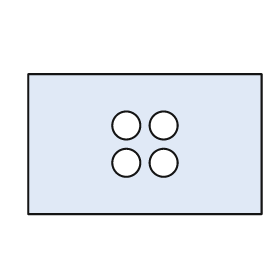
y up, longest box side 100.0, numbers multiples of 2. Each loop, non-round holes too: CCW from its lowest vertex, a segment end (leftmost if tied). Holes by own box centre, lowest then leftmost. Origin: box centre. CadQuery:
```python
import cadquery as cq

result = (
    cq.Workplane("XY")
    .moveTo(-50.0, -30.0)
    .lineTo(50.0, -30.0)
    .lineTo(50.0, 30.0)
    .lineTo(-50.0, 30.0)
    .close()
    .moveTo(-8.0, -8.0)
    .circle(6.0)
    .moveTo(8.0, -8.0)
    .circle(6.0)
    .moveTo(-8.0, 8.0)
    .circle(6.0)
    .moveTo(8.0, 8.0)
    .circle(6.0)
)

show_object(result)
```